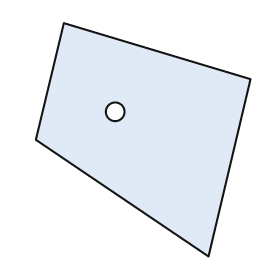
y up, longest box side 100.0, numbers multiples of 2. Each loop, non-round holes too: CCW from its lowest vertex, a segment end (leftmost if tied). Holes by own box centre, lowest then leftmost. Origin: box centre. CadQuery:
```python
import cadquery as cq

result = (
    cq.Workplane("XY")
    .moveTo(28.0, -50.0)
    .lineTo(46.0, 26.0)
    .lineTo(-34.0, 50.0)
    .lineTo(-46.0, 0.0)
    .close()
    .moveTo(-12.0, 12.0)
    .circle(4.0)
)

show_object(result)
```